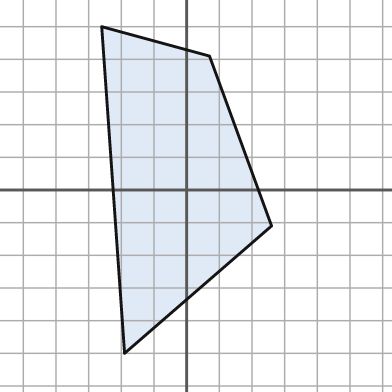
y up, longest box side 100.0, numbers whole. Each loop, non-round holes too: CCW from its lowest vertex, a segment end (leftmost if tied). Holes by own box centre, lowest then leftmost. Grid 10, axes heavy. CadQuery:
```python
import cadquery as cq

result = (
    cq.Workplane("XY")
    .moveTo(-19.0, -50.0)
    .lineTo(26.0, -11.0)
    .lineTo(7.0, 41.0)
    .lineTo(-26.0, 50.0)
    .close()
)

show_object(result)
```